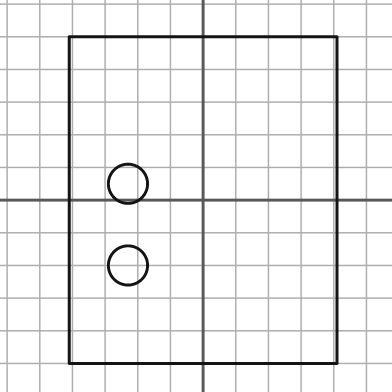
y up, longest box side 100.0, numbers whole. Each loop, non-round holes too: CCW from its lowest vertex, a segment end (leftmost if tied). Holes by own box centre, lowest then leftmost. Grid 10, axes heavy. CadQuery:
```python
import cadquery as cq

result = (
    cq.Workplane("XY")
    .moveTo(-41.0, -50.0)
    .lineTo(41.0, -50.0)
    .lineTo(41.0, 50.0)
    .lineTo(-41.0, 50.0)
    .close()
    .moveTo(-23.0, -20.0)
    .circle(6.0)
    .moveTo(-23.0, 5.0)
    .circle(6.0)
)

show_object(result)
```